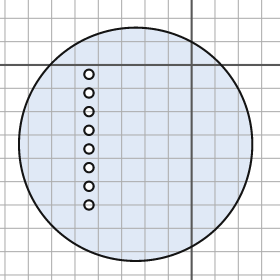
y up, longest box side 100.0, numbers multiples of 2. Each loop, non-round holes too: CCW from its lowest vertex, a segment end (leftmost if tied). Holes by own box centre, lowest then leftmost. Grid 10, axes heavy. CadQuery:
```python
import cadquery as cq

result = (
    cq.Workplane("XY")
    .moveTo(-24.0, -34.0)
    .circle(50.0)
    .moveTo(-44.0, -60.0)
    .circle(2.0)
    .moveTo(-44.0, -52.0)
    .circle(2.0)
    .moveTo(-44.0, -44.0)
    .circle(2.0)
    .moveTo(-44.0, -36.0)
    .circle(2.0)
    .moveTo(-44.0, -28.0)
    .circle(2.0)
    .moveTo(-44.0, -20.0)
    .circle(2.0)
    .moveTo(-44.0, -12.0)
    .circle(2.0)
    .moveTo(-44.0, -4.0)
    .circle(2.0)
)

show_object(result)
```